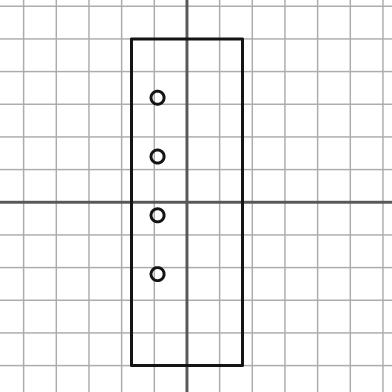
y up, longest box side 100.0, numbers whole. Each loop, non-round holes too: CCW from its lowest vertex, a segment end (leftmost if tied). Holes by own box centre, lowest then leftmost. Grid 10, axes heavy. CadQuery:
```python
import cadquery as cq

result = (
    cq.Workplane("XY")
    .moveTo(-17.0, -50.0)
    .lineTo(17.0, -50.0)
    .lineTo(17.0, 50.0)
    .lineTo(-17.0, 50.0)
    .close()
    .moveTo(-9.0, -22.0)
    .circle(2.0)
    .moveTo(-9.0, -4.0)
    .circle(2.0)
    .moveTo(-9.0, 14.0)
    .circle(2.0)
    .moveTo(-9.0, 32.0)
    .circle(2.0)
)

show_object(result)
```